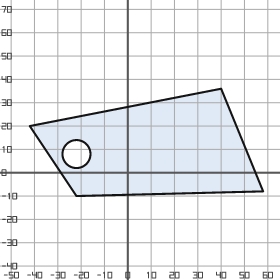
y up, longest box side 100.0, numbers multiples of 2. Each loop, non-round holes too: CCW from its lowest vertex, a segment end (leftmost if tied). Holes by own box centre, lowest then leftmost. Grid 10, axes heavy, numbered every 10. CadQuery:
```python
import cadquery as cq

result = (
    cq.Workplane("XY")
    .moveTo(-22.0, -10.0)
    .lineTo(58.0, -8.0)
    .lineTo(40.0, 36.0)
    .lineTo(-42.0, 20.0)
    .close()
    .moveTo(-22.0, 8.0)
    .circle(6.0)
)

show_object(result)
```